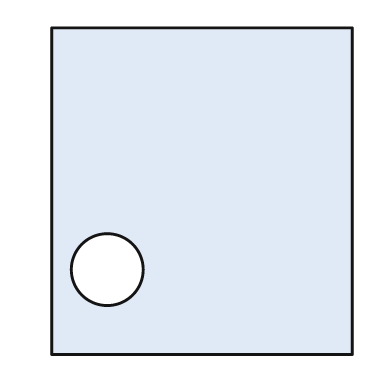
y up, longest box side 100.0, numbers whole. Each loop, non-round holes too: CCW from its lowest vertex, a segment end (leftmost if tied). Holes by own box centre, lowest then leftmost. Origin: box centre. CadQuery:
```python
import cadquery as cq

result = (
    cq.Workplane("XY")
    .moveTo(-46.0, -50.0)
    .lineTo(46.0, -50.0)
    .lineTo(46.0, 50.0)
    .lineTo(-46.0, 50.0)
    .close()
    .moveTo(-29.0, -24.0)
    .circle(11.0)
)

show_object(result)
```